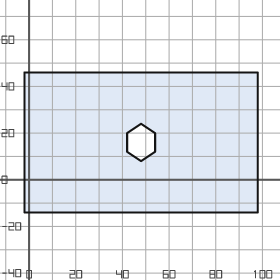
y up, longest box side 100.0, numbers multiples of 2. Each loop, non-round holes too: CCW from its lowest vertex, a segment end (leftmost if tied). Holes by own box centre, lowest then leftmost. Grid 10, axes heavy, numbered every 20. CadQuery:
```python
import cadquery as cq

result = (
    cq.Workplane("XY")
    .moveTo(-2.0, -14.0)
    .lineTo(98.0, -14.0)
    .lineTo(98.0, 46.0)
    .lineTo(-2.0, 46.0)
    .close()
    .moveTo(48.0, 8.0)
    .lineTo(54.0, 12.0)
    .lineTo(54.0, 20.0)
    .lineTo(48.0, 24.0)
    .lineTo(42.0, 20.0)
    .lineTo(42.0, 12.0)
    .close()
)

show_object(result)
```